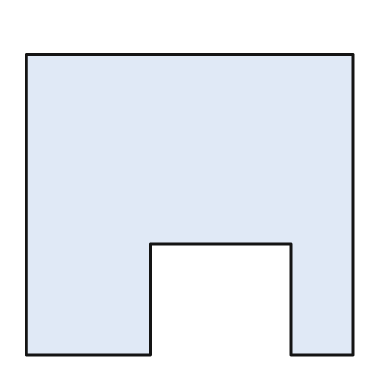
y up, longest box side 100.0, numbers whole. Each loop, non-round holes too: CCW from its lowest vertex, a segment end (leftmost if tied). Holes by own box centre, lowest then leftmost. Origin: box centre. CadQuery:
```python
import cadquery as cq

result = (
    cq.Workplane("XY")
    .moveTo(-50.0, -46.0)
    .lineTo(-12.0, -46.0)
    .lineTo(-12.0, -12.0)
    .lineTo(31.0, -12.0)
    .lineTo(31.0, -46.0)
    .lineTo(50.0, -46.0)
    .lineTo(50.0, 46.0)
    .lineTo(-50.0, 46.0)
    .close()
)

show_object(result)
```